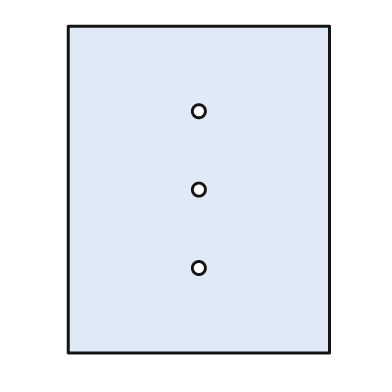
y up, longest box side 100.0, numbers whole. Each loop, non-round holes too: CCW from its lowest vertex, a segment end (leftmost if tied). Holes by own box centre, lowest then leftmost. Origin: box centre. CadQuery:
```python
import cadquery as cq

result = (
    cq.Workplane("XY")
    .moveTo(-40.0, -50.0)
    .lineTo(40.0, -50.0)
    .lineTo(40.0, 50.0)
    .lineTo(-40.0, 50.0)
    .close()
    .moveTo(0.0, -24.0)
    .circle(2.0)
    .moveTo(0.0, 0.0)
    .circle(2.0)
    .moveTo(0.0, 24.0)
    .circle(2.0)
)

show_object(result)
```